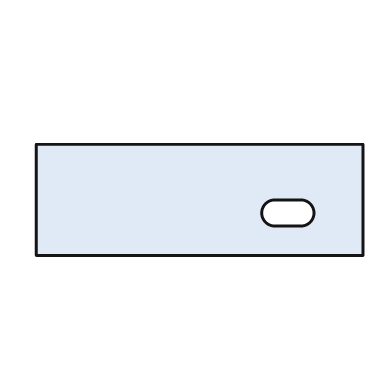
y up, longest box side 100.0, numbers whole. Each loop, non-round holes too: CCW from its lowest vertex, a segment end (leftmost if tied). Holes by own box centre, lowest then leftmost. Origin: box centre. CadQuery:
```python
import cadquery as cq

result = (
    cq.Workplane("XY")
    .moveTo(-50.0, -17.0)
    .lineTo(50.0, -17.0)
    .lineTo(50.0, 17.0)
    .lineTo(-50.0, 17.0)
    .close()
    .moveTo(23.0, -8.0)
    .lineTo(31.0, -8.0)
    .threePointArc((35.0, -4.0), (31.0, 0.0))
    .lineTo(23.0, 0.0)
    .threePointArc((19.0, -4.0), (23.0, -8.0))
    .close()
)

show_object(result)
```